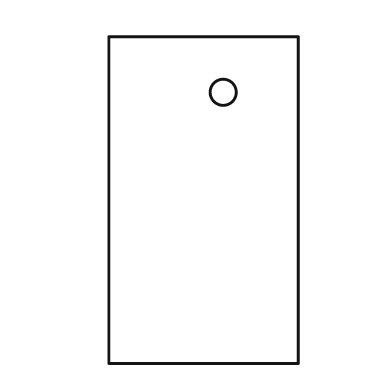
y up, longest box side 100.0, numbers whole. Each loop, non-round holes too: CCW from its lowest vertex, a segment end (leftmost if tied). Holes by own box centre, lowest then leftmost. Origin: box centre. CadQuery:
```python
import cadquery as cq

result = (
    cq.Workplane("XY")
    .moveTo(-29.0, -50.0)
    .lineTo(29.0, -50.0)
    .lineTo(29.0, 50.0)
    .lineTo(-29.0, 50.0)
    .close()
    .moveTo(6.0, 33.0)
    .circle(4.0)
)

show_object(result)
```